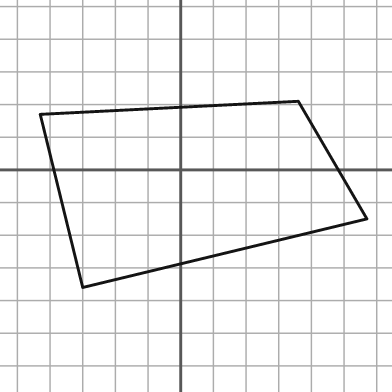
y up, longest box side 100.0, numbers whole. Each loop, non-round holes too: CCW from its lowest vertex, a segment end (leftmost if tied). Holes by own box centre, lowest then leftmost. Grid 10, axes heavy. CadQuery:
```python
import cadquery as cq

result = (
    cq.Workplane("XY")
    .moveTo(-30.0, -36.0)
    .lineTo(57.0, -15.0)
    .lineTo(36.0, 21.0)
    .lineTo(-43.0, 17.0)
    .close()
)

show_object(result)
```